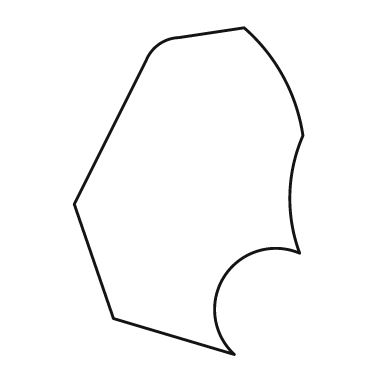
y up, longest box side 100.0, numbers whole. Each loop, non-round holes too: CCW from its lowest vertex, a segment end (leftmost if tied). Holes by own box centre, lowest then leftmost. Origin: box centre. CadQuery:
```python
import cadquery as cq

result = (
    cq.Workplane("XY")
    .moveTo(14.0, -50.0)
    .threePointArc((11.0, -26.0), (34.0, -19.0))
    .threePointArc((31.0, -1.0), (35.0, 17.0))
    .threePointArc((29.0, 35.0), (17.0, 50.0))
    .lineTo(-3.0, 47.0)
    .threePointArc((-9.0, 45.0), (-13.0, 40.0))
    .lineTo(-35.0, -4.0)
    .lineTo(-23.0, -39.0)
    .close()
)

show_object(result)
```